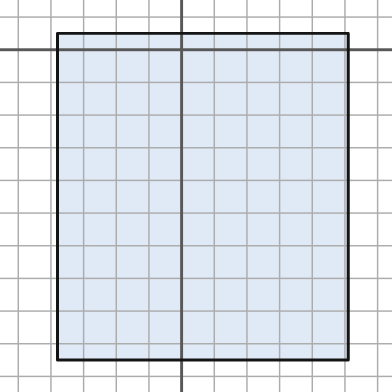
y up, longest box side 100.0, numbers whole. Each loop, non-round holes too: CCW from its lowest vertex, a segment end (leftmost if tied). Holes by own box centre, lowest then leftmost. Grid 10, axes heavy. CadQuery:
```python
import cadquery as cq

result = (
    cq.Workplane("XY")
    .moveTo(-38.0, -95.0)
    .lineTo(51.0, -95.0)
    .lineTo(51.0, 5.0)
    .lineTo(-38.0, 5.0)
    .close()
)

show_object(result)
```